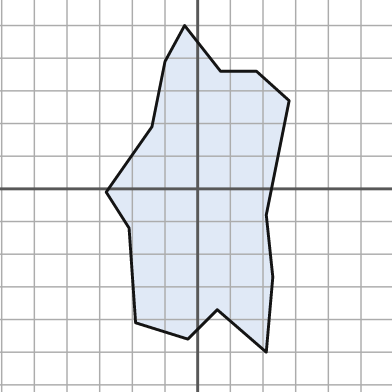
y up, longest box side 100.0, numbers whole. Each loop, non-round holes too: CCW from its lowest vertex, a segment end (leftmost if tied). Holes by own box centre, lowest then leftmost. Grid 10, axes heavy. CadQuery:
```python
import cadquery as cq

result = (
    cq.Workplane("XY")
    .moveTo(21.0, -50.0)
    .lineTo(23.0, -27.0)
    .lineTo(21.0, -8.0)
    .lineTo(28.0, 27.0)
    .lineTo(18.0, 36.0)
    .lineTo(7.0, 36.0)
    .lineTo(-4.0, 50.0)
    .lineTo(-10.0, 39.0)
    .lineTo(-14.0, 19.0)
    .lineTo(-28.0, -1.0)
    .lineTo(-21.0, -12.0)
    .lineTo(-19.0, -41.0)
    .lineTo(-3.0, -46.0)
    .lineTo(6.0, -37.0)
    .close()
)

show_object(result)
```